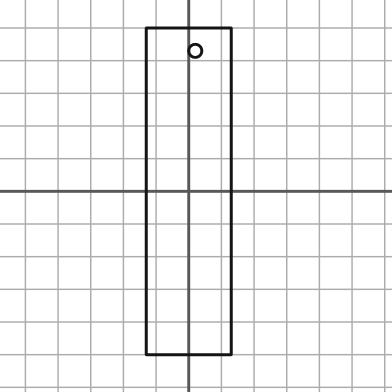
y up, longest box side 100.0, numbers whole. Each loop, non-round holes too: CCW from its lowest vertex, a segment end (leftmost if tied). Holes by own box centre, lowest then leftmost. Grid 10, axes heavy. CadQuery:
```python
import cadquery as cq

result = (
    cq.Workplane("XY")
    .moveTo(-13.0, -50.0)
    .lineTo(13.0, -50.0)
    .lineTo(13.0, 50.0)
    .lineTo(-13.0, 50.0)
    .close()
    .moveTo(2.0, 43.0)
    .circle(2.0)
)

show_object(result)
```